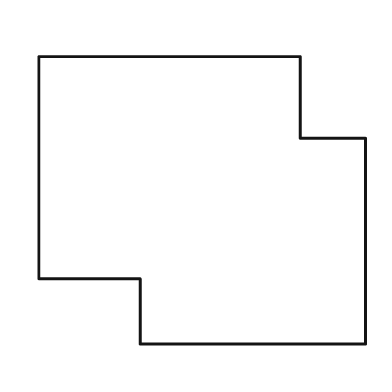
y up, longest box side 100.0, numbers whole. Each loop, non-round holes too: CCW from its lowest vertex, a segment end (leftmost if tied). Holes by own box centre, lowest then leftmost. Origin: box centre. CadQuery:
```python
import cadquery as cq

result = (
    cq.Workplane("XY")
    .moveTo(-19.0, -44.0)
    .lineTo(50.0, -44.0)
    .lineTo(50.0, 19.0)
    .lineTo(30.0, 19.0)
    .lineTo(30.0, 44.0)
    .lineTo(-50.0, 44.0)
    .lineTo(-50.0, -24.0)
    .lineTo(-19.0, -24.0)
    .close()
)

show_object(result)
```